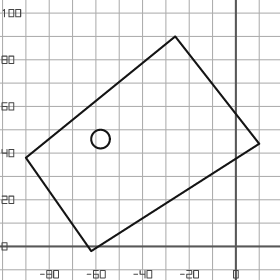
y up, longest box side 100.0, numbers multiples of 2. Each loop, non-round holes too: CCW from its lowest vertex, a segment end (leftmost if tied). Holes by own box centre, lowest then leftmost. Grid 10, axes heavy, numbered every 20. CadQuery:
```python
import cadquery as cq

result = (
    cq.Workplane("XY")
    .moveTo(-62.0, -2.0)
    .lineTo(10.0, 44.0)
    .lineTo(-26.0, 90.0)
    .lineTo(-90.0, 38.0)
    .close()
    .moveTo(-58.0, 46.0)
    .circle(4.0)
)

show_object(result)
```